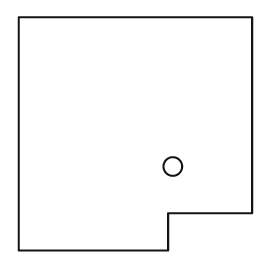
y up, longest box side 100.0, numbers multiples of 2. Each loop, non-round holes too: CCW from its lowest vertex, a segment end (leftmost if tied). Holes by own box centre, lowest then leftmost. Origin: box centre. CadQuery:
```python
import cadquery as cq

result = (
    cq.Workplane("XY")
    .moveTo(-50.0, -50.0)
    .lineTo(14.0, -50.0)
    .lineTo(14.0, -34.0)
    .lineTo(50.0, -34.0)
    .lineTo(50.0, 50.0)
    .lineTo(-50.0, 50.0)
    .close()
    .moveTo(16.0, -14.0)
    .circle(4.0)
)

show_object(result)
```